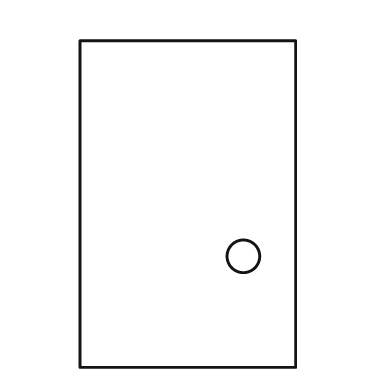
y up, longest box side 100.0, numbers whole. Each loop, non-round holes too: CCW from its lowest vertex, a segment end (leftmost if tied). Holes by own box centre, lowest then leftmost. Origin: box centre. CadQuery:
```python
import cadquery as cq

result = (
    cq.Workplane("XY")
    .moveTo(-33.0, -50.0)
    .lineTo(33.0, -50.0)
    .lineTo(33.0, 50.0)
    .lineTo(-33.0, 50.0)
    .close()
    .moveTo(17.0, -16.0)
    .circle(5.0)
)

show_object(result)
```